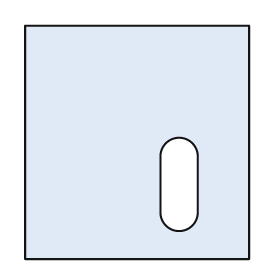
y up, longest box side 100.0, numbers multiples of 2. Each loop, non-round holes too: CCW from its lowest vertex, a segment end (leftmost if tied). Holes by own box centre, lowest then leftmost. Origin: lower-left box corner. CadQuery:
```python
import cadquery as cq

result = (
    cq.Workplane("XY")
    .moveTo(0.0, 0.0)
    .lineTo(96.0, 0.0)
    .lineTo(96.0, 100.0)
    .lineTo(0.0, 100.0)
    .close()
    .moveTo(58.0, 20.0)
    .threePointArc((66.0, 12.0), (74.0, 20.0))
    .lineTo(74.0, 44.0)
    .threePointArc((66.0, 52.0), (58.0, 44.0))
    .close()
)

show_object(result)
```